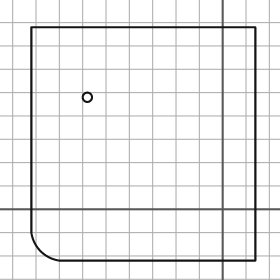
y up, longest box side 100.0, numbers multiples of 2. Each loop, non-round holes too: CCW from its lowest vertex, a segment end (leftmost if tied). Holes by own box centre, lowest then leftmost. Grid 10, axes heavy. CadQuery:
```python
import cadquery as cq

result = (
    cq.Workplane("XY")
    .moveTo(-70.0, -22.0)
    .lineTo(14.0, -22.0)
    .lineTo(14.0, 78.0)
    .lineTo(-82.0, 78.0)
    .lineTo(-82.0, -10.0)
    .threePointArc((-78.0, -18.0), (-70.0, -22.0))
    .close()
    .moveTo(-58.0, 48.0)
    .circle(2.0)
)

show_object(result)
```